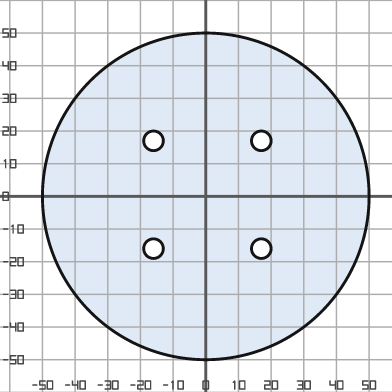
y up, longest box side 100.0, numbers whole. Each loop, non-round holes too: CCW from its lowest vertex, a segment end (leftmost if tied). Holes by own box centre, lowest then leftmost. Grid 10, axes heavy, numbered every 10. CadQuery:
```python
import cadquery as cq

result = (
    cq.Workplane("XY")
    .moveTo(0.0, 0.0)
    .circle(50.0)
    .moveTo(-16.0, -16.0)
    .circle(3.0)
    .moveTo(17.0, -16.0)
    .circle(3.0)
    .moveTo(-16.0, 17.0)
    .circle(3.0)
    .moveTo(17.0, 17.0)
    .circle(3.0)
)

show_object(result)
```